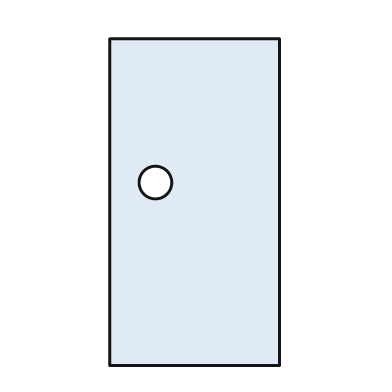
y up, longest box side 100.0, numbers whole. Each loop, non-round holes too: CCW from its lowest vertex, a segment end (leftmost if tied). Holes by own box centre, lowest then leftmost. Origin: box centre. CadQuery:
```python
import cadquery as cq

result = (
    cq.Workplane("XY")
    .moveTo(-26.0, -50.0)
    .lineTo(26.0, -50.0)
    .lineTo(26.0, 50.0)
    .lineTo(-26.0, 50.0)
    .close()
    .moveTo(-12.0, 6.0)
    .circle(5.0)
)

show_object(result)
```